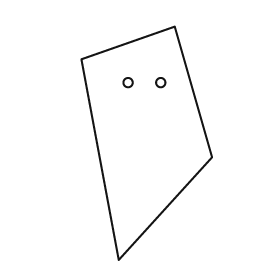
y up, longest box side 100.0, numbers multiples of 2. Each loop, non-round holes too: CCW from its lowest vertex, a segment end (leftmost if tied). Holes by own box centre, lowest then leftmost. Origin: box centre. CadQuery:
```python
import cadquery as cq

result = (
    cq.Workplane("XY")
    .moveTo(-12.0, -50.0)
    .lineTo(28.0, -6.0)
    .lineTo(12.0, 50.0)
    .lineTo(-28.0, 36.0)
    .close()
    .moveTo(-8.0, 26.0)
    .circle(2.0)
    .moveTo(6.0, 26.0)
    .circle(2.0)
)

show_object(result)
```